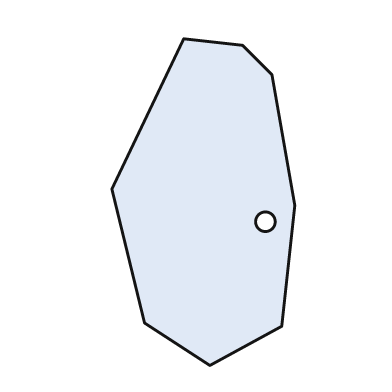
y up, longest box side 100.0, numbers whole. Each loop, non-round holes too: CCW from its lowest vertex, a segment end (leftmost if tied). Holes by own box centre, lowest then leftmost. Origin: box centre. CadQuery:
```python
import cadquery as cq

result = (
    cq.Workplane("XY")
    .moveTo(2.0, -50.0)
    .lineTo(24.0, -38.0)
    .lineTo(28.0, -1.0)
    .lineTo(21.0, 39.0)
    .lineTo(12.0, 48.0)
    .lineTo(-6.0, 50.0)
    .lineTo(-28.0, 4.0)
    .lineTo(-18.0, -37.0)
    .close()
    .moveTo(19.0, -6.0)
    .circle(3.0)
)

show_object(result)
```